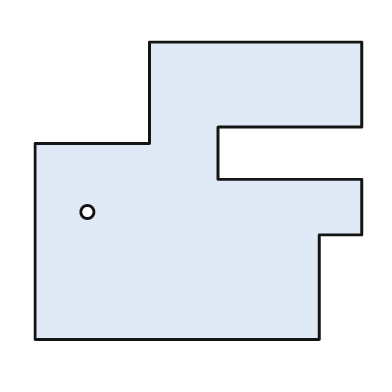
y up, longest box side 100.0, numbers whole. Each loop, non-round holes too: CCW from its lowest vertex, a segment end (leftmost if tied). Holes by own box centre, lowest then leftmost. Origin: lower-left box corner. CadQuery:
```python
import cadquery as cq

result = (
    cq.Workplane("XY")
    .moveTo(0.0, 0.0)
    .lineTo(87.0, 0.0)
    .lineTo(87.0, 32.0)
    .lineTo(100.0, 32.0)
    .lineTo(100.0, 49.0)
    .lineTo(56.0, 49.0)
    .lineTo(56.0, 65.0)
    .lineTo(100.0, 65.0)
    .lineTo(100.0, 91.0)
    .lineTo(35.0, 91.0)
    .lineTo(35.0, 60.0)
    .lineTo(0.0, 60.0)
    .close()
    .moveTo(16.0, 39.0)
    .circle(2.0)
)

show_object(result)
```